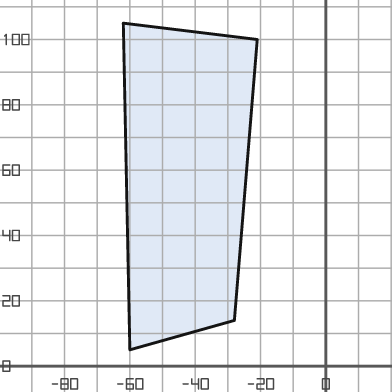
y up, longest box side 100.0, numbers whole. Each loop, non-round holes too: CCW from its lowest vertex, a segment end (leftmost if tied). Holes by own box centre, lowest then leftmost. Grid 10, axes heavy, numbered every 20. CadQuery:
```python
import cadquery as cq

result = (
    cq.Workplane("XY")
    .moveTo(-60.0, 5.0)
    .lineTo(-28.0, 14.0)
    .lineTo(-21.0, 100.0)
    .lineTo(-62.0, 105.0)
    .close()
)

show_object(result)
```